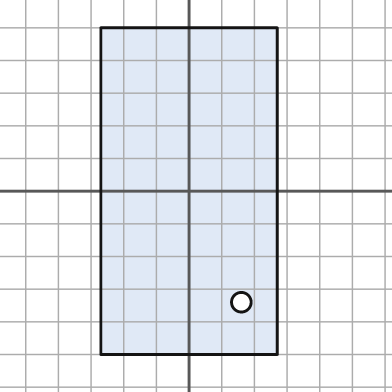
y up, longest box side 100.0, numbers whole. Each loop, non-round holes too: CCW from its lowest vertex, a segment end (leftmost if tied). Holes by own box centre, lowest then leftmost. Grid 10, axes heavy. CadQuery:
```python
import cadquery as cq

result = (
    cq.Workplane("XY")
    .moveTo(-27.0, -50.0)
    .lineTo(27.0, -50.0)
    .lineTo(27.0, 50.0)
    .lineTo(-27.0, 50.0)
    .close()
    .moveTo(16.0, -34.0)
    .circle(3.0)
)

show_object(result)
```